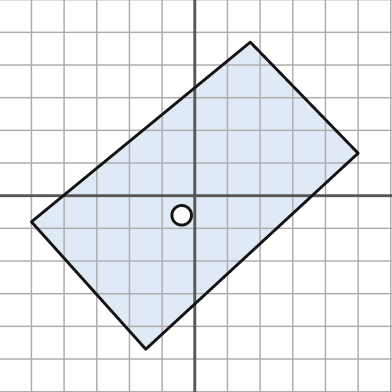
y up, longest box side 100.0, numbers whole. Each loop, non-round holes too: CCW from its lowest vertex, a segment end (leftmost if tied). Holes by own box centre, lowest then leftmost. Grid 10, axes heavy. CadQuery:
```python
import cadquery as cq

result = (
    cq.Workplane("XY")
    .moveTo(-15.0, -47.0)
    .lineTo(50.0, 13.0)
    .lineTo(17.0, 47.0)
    .lineTo(-50.0, -8.0)
    .close()
    .moveTo(-4.0, -6.0)
    .circle(3.0)
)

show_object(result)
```